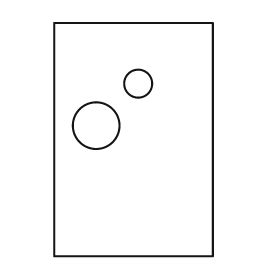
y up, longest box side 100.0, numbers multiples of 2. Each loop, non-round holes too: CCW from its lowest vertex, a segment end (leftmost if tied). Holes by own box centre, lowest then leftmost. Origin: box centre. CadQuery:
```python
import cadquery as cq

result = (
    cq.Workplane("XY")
    .moveTo(-34.0, -50.0)
    .lineTo(34.0, -50.0)
    .lineTo(34.0, 50.0)
    .lineTo(-34.0, 50.0)
    .close()
    .moveTo(-16.0, 6.0)
    .circle(10.0)
    .moveTo(2.0, 24.0)
    .circle(6.0)
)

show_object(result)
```